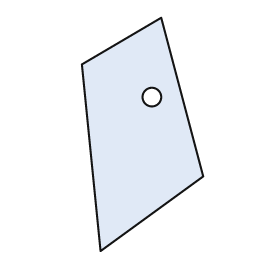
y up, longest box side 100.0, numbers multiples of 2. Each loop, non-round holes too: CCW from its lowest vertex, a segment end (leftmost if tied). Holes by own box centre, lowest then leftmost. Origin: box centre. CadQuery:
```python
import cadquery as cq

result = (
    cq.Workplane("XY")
    .moveTo(-18.0, -50.0)
    .lineTo(26.0, -18.0)
    .lineTo(8.0, 50.0)
    .lineTo(-26.0, 30.0)
    .close()
    .moveTo(4.0, 16.0)
    .circle(4.0)
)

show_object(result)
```